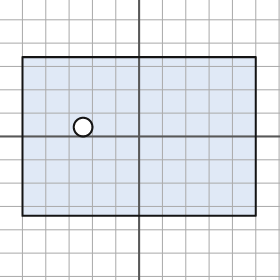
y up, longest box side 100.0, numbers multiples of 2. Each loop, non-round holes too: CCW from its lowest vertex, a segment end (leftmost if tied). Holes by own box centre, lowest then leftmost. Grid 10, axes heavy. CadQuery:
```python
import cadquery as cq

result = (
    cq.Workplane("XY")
    .moveTo(-50.0, -34.0)
    .lineTo(50.0, -34.0)
    .lineTo(50.0, 34.0)
    .lineTo(-50.0, 34.0)
    .close()
    .moveTo(-24.0, 4.0)
    .circle(4.0)
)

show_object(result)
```